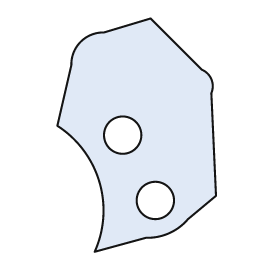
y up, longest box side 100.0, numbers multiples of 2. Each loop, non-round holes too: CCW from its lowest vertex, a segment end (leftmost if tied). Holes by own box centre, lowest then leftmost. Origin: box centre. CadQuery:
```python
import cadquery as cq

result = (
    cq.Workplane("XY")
    .moveTo(-18.0, -50.0)
    .lineTo(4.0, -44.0)
    .threePointArc((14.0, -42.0), (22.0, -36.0))
    .lineTo(34.0, -26.0)
    .lineTo(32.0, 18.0)
    .threePointArc((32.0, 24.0), (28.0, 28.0))
    .lineTo(6.0, 50.0)
    .lineTo(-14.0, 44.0)
    .threePointArc((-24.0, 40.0), (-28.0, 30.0))
    .lineTo(-34.0, 4.0)
    .threePointArc((-16.0, -20.0), (-18.0, -50.0))
    .close()
    .moveTo(8.0, -28.0)
    .circle(8.0)
    .moveTo(-6.0, 0.0)
    .circle(8.0)
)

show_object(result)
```